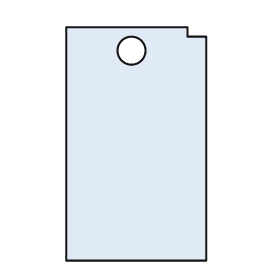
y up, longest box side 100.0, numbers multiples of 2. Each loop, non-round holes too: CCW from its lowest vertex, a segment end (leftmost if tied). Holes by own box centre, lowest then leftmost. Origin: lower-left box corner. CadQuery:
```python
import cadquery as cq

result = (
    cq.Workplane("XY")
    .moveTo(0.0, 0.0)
    .lineTo(60.0, 0.0)
    .lineTo(60.0, 96.0)
    .lineTo(52.0, 96.0)
    .lineTo(52.0, 100.0)
    .lineTo(0.0, 100.0)
    .close()
    .moveTo(28.0, 90.0)
    .circle(6.0)
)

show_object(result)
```